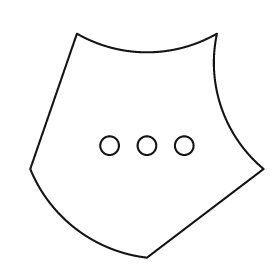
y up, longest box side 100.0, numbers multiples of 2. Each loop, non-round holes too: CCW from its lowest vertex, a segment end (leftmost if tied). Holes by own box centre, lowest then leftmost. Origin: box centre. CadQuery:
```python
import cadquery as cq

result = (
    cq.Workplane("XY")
    .moveTo(0.0, -48.0)
    .lineTo(50.0, -10.0)
    .threePointArc((32.0, 16.0), (30.0, 48.0))
    .threePointArc((0.0, 40.0), (-30.0, 48.0))
    .lineTo(-50.0, -10.0)
    .threePointArc((-30.0, -36.0), (0.0, -48.0))
    .close()
    .moveTo(-16.0, 0.0)
    .circle(4.0)
    .moveTo(0.0, 0.0)
    .circle(4.0)
    .moveTo(16.0, 0.0)
    .circle(4.0)
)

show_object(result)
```